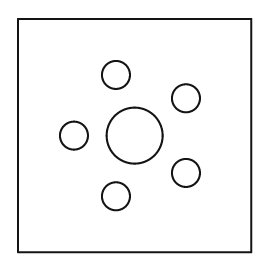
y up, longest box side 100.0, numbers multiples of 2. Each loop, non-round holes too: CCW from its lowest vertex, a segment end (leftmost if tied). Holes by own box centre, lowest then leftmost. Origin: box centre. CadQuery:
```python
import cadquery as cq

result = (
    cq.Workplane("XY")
    .moveTo(-50.0, -50.0)
    .lineTo(50.0, -50.0)
    .lineTo(50.0, 50.0)
    .lineTo(-50.0, 50.0)
    .close()
    .moveTo(-8.0, -26.0)
    .circle(6.0)
    .moveTo(22.0, -16.0)
    .circle(6.0)
    .moveTo(-26.0, 0.0)
    .circle(6.0)
    .moveTo(0.0, 0.0)
    .circle(12.0)
    .moveTo(22.0, 16.0)
    .circle(6.0)
    .moveTo(-8.0, 26.0)
    .circle(6.0)
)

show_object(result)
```